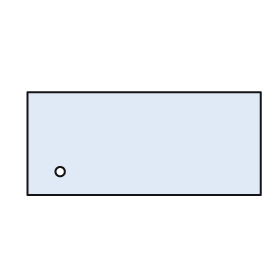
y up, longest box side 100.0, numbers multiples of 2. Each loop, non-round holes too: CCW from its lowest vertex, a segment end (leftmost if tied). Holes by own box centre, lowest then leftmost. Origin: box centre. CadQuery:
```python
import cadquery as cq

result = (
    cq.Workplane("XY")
    .moveTo(-50.0, -22.0)
    .lineTo(50.0, -22.0)
    .lineTo(50.0, 22.0)
    .lineTo(-50.0, 22.0)
    .close()
    .moveTo(-36.0, -12.0)
    .circle(2.0)
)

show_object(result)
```